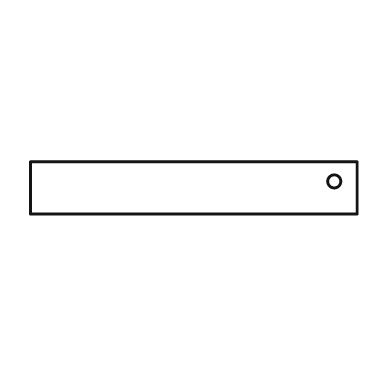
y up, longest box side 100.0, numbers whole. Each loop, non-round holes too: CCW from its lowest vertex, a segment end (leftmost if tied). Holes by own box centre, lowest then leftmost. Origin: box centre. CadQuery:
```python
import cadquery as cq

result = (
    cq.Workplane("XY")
    .moveTo(-50.0, -8.0)
    .lineTo(50.0, -8.0)
    .lineTo(50.0, 8.0)
    .lineTo(-50.0, 8.0)
    .close()
    .moveTo(43.0, 2.0)
    .circle(2.0)
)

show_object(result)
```